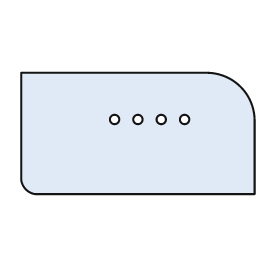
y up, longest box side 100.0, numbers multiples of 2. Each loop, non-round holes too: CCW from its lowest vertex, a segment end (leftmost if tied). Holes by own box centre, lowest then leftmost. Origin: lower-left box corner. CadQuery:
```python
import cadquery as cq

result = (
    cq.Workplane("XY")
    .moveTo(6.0, 0.0)
    .lineTo(100.0, 0.0)
    .lineTo(100.0, 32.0)
    .threePointArc((94.0, 46.0), (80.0, 52.0))
    .lineTo(0.0, 52.0)
    .lineTo(0.0, 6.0)
    .threePointArc((2.0, 2.0), (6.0, 0.0))
    .close()
    .moveTo(40.0, 32.0)
    .circle(2.0)
    .moveTo(50.0, 32.0)
    .circle(2.0)
    .moveTo(60.0, 32.0)
    .circle(2.0)
    .moveTo(70.0, 32.0)
    .circle(2.0)
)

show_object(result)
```